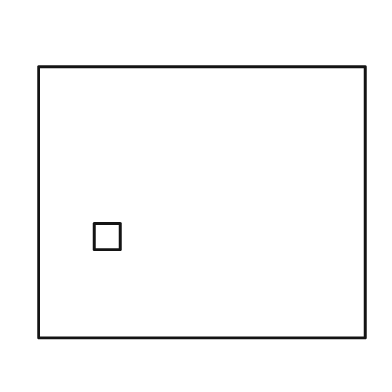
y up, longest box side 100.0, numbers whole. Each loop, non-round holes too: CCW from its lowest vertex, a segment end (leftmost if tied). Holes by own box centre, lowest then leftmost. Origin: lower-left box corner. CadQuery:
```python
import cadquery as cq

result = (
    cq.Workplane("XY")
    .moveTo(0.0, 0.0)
    .lineTo(100.0, 0.0)
    .lineTo(100.0, 83.0)
    .lineTo(0.0, 83.0)
    .close()
    .moveTo(17.0, 27.0)
    .lineTo(25.0, 27.0)
    .lineTo(25.0, 35.0)
    .lineTo(17.0, 35.0)
    .close()
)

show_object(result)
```